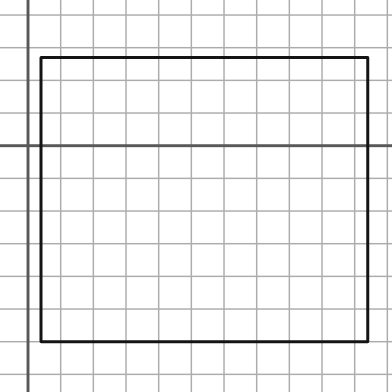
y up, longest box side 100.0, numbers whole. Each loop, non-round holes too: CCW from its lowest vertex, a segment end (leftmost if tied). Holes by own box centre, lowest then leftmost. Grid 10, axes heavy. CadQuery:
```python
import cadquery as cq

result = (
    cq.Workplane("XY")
    .moveTo(4.0, -60.0)
    .lineTo(104.0, -60.0)
    .lineTo(104.0, 27.0)
    .lineTo(4.0, 27.0)
    .close()
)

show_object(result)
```